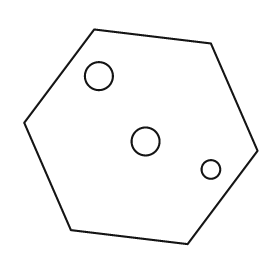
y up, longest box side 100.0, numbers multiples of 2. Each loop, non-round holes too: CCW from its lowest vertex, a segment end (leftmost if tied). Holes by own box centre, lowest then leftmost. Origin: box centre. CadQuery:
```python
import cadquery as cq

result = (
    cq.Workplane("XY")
    .moveTo(20.0, -46.0)
    .lineTo(50.0, -6.0)
    .lineTo(30.0, 40.0)
    .lineTo(-20.0, 46.0)
    .lineTo(-50.0, 6.0)
    .lineTo(-30.0, -40.0)
    .close()
    .moveTo(30.0, -14.0)
    .circle(4.0)
    .moveTo(2.0, -2.0)
    .circle(6.0)
    .moveTo(-18.0, 26.0)
    .circle(6.0)
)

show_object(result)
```